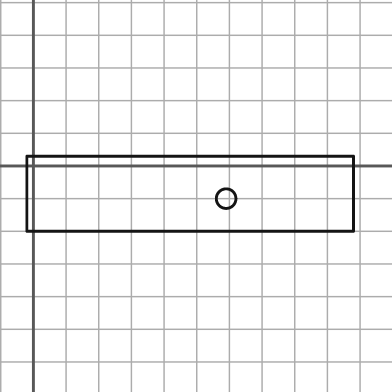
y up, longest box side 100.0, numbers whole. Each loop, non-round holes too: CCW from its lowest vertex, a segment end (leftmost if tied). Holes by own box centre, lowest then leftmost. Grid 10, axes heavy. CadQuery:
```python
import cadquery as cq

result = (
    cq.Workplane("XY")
    .moveTo(-2.0, -20.0)
    .lineTo(98.0, -20.0)
    .lineTo(98.0, 3.0)
    .lineTo(-2.0, 3.0)
    .close()
    .moveTo(59.0, -10.0)
    .circle(3.0)
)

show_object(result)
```